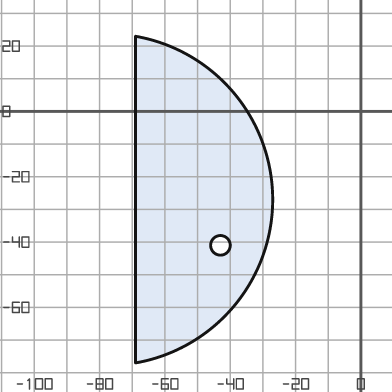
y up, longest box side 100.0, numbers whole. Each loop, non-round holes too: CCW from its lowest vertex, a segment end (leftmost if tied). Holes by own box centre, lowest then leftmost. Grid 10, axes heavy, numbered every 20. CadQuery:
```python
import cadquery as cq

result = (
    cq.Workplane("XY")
    .moveTo(-69.0, -77.0)
    .threePointArc((-27.0, -27.0), (-69.0, 23.0))
    .close()
    .moveTo(-43.0, -41.0)
    .circle(3.0)
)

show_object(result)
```